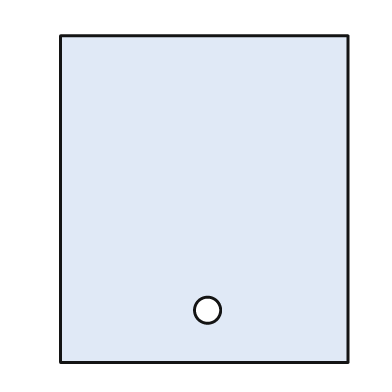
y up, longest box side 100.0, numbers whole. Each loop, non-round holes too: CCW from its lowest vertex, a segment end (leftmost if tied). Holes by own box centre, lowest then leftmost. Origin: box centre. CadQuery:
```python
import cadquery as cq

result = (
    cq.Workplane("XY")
    .moveTo(-44.0, -50.0)
    .lineTo(44.0, -50.0)
    .lineTo(44.0, 50.0)
    .lineTo(-44.0, 50.0)
    .close()
    .moveTo(1.0, -34.0)
    .circle(4.0)
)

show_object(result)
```